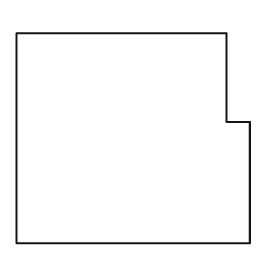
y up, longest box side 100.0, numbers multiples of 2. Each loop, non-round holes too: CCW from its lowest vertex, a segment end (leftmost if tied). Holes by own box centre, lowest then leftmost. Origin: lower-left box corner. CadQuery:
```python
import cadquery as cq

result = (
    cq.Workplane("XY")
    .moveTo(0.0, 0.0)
    .lineTo(100.0, 0.0)
    .lineTo(100.0, 52.0)
    .lineTo(90.0, 52.0)
    .lineTo(90.0, 90.0)
    .lineTo(0.0, 90.0)
    .close()
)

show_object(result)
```